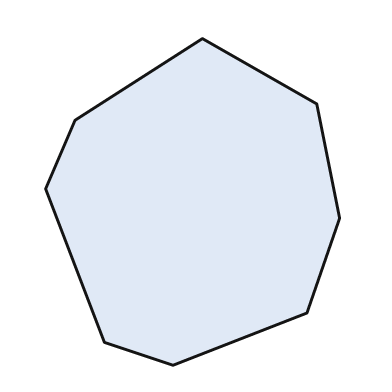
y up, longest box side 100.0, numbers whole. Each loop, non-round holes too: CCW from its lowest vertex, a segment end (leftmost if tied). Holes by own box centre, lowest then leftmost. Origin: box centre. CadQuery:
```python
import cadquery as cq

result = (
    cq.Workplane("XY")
    .moveTo(-6.0, -50.0)
    .lineTo(35.0, -34.0)
    .lineTo(45.0, -5.0)
    .lineTo(38.0, 30.0)
    .lineTo(3.0, 50.0)
    .lineTo(-36.0, 25.0)
    .lineTo(-45.0, 4.0)
    .lineTo(-27.0, -43.0)
    .close()
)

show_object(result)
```